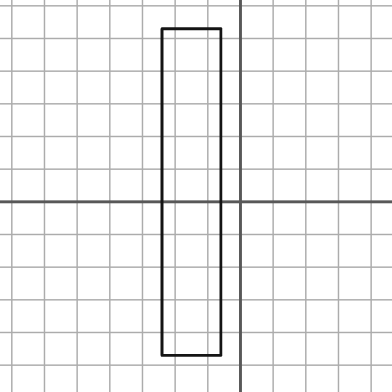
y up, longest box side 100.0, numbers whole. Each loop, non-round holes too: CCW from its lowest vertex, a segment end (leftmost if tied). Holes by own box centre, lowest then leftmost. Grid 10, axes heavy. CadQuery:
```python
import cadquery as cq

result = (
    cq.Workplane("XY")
    .moveTo(-24.0, -47.0)
    .lineTo(-6.0, -47.0)
    .lineTo(-6.0, 53.0)
    .lineTo(-24.0, 53.0)
    .close()
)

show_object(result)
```